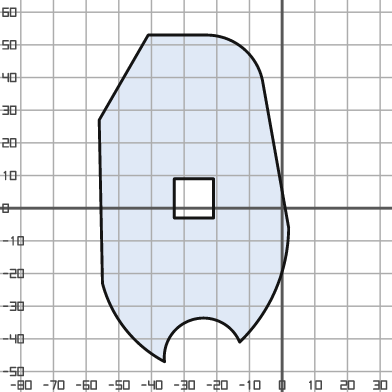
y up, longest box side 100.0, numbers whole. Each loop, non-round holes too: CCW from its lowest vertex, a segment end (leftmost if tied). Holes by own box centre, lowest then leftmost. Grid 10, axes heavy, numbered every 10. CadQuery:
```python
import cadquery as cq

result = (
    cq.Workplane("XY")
    .moveTo(-36.0, -47.0)
    .threePointArc((-27.0, -34.0), (-13.0, -41.0))
    .threePointArc((-2.0, -25.0), (2.0, -6.0))
    .lineTo(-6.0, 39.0)
    .threePointArc((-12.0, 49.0), (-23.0, 53.0))
    .lineTo(-41.0, 53.0)
    .lineTo(-56.0, 27.0)
    .lineTo(-55.0, -23.0)
    .threePointArc((-48.0, -37.0), (-36.0, -47.0))
    .close()
    .moveTo(-33.0, -3.0)
    .lineTo(-21.0, -3.0)
    .lineTo(-21.0, 9.0)
    .lineTo(-33.0, 9.0)
    .close()
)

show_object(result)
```